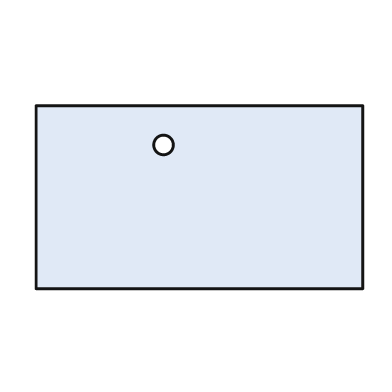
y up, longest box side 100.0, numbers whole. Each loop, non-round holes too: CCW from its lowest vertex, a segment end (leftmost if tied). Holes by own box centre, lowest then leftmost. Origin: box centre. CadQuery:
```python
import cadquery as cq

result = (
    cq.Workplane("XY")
    .moveTo(-50.0, -28.0)
    .lineTo(50.0, -28.0)
    .lineTo(50.0, 28.0)
    .lineTo(-50.0, 28.0)
    .close()
    .moveTo(-11.0, 16.0)
    .circle(3.0)
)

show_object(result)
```